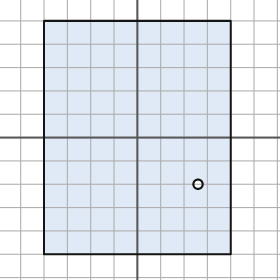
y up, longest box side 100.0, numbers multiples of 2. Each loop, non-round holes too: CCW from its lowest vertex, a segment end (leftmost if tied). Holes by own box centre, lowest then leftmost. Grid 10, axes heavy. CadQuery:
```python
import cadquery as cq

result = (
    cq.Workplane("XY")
    .moveTo(-40.0, -50.0)
    .lineTo(40.0, -50.0)
    .lineTo(40.0, 50.0)
    .lineTo(-40.0, 50.0)
    .close()
    .moveTo(26.0, -20.0)
    .circle(2.0)
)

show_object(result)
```